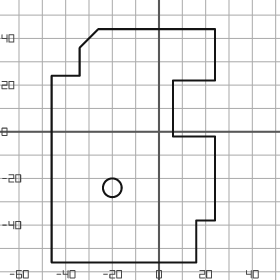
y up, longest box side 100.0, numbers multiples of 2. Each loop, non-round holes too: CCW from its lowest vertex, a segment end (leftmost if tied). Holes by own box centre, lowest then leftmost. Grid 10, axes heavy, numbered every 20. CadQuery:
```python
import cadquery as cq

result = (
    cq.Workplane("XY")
    .moveTo(-46.0, -56.0)
    .lineTo(16.0, -56.0)
    .lineTo(16.0, -38.0)
    .lineTo(24.0, -38.0)
    .lineTo(24.0, -2.0)
    .lineTo(6.0, -2.0)
    .lineTo(6.0, 22.0)
    .lineTo(24.0, 22.0)
    .lineTo(24.0, 44.0)
    .lineTo(-26.0, 44.0)
    .lineTo(-34.0, 36.0)
    .lineTo(-34.0, 24.0)
    .lineTo(-46.0, 24.0)
    .close()
    .moveTo(-20.0, -24.0)
    .circle(4.0)
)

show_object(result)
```